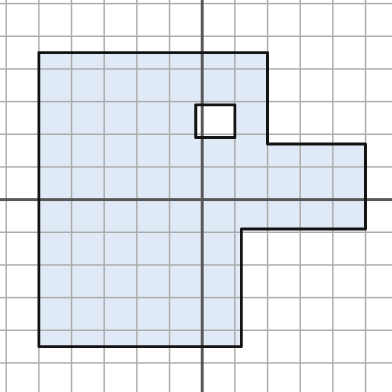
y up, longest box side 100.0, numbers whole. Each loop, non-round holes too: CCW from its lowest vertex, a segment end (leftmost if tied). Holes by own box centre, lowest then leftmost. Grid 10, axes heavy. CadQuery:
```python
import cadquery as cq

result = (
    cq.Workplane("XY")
    .moveTo(-50.0, -45.0)
    .lineTo(12.0, -45.0)
    .lineTo(12.0, -9.0)
    .lineTo(50.0, -9.0)
    .lineTo(50.0, 17.0)
    .lineTo(20.0, 17.0)
    .lineTo(20.0, 45.0)
    .lineTo(-50.0, 45.0)
    .close()
    .moveTo(-2.0, 19.0)
    .lineTo(10.0, 19.0)
    .lineTo(10.0, 29.0)
    .lineTo(-2.0, 29.0)
    .close()
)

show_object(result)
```